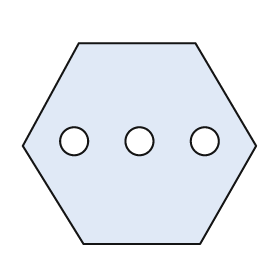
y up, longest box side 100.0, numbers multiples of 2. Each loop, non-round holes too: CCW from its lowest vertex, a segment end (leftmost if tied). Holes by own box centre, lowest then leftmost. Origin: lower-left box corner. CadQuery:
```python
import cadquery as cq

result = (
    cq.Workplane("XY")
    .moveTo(26.0, 0.0)
    .lineTo(76.0, 0.0)
    .lineTo(100.0, 42.0)
    .lineTo(74.0, 86.0)
    .lineTo(24.0, 86.0)
    .lineTo(0.0, 42.0)
    .close()
    .moveTo(22.0, 44.0)
    .circle(6.0)
    .moveTo(50.0, 44.0)
    .circle(6.0)
    .moveTo(78.0, 44.0)
    .circle(6.0)
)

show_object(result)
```